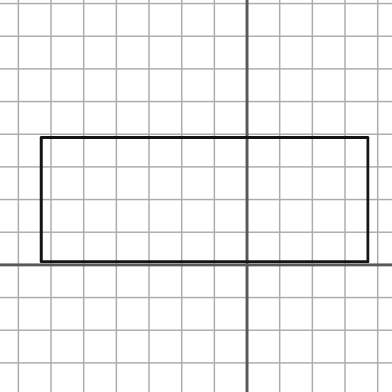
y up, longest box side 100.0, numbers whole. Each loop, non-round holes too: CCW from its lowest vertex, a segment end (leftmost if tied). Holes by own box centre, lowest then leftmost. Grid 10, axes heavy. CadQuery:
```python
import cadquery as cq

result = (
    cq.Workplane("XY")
    .moveTo(-63.0, 1.0)
    .lineTo(37.0, 1.0)
    .lineTo(37.0, 39.0)
    .lineTo(-63.0, 39.0)
    .close()
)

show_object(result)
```